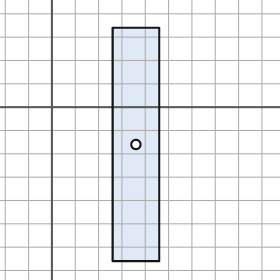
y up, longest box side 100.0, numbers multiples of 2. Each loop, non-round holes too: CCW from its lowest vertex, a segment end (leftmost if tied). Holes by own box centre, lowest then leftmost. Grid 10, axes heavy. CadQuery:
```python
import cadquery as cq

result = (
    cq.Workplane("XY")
    .moveTo(26.0, -66.0)
    .lineTo(46.0, -66.0)
    .lineTo(46.0, 34.0)
    .lineTo(26.0, 34.0)
    .close()
    .moveTo(36.0, -16.0)
    .circle(2.0)
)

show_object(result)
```